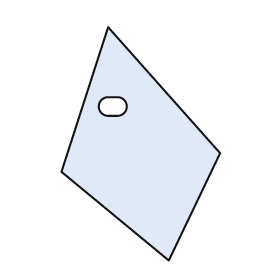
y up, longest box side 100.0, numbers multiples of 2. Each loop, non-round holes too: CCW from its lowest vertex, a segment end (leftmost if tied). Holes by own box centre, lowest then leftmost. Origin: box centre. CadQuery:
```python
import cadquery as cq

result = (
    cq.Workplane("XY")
    .moveTo(12.0, -50.0)
    .lineTo(34.0, -4.0)
    .lineTo(-14.0, 50.0)
    .lineTo(-34.0, -12.0)
    .close()
    .moveTo(-14.0, 12.0)
    .lineTo(-10.0, 12.0)
    .threePointArc((-6.0, 16.0), (-10.0, 20.0))
    .lineTo(-14.0, 20.0)
    .threePointArc((-18.0, 16.0), (-14.0, 12.0))
    .close()
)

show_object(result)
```